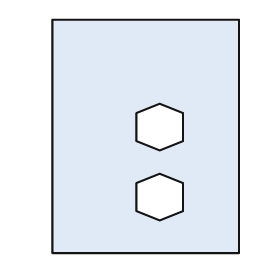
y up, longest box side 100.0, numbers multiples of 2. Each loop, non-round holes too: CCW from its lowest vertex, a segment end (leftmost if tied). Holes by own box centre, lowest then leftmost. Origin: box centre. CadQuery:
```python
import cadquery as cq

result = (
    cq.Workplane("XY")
    .moveTo(-40.0, -50.0)
    .lineTo(40.0, -50.0)
    .lineTo(40.0, 50.0)
    .lineTo(-40.0, 50.0)
    .close()
    .moveTo(6.0, -36.0)
    .lineTo(16.0, -32.0)
    .lineTo(16.0, -20.0)
    .lineTo(6.0, -16.0)
    .lineTo(-4.0, -20.0)
    .lineTo(-4.0, -32.0)
    .close()
    .moveTo(6.0, -6.0)
    .lineTo(16.0, -2.0)
    .lineTo(16.0, 10.0)
    .lineTo(6.0, 14.0)
    .lineTo(-4.0, 10.0)
    .lineTo(-4.0, -2.0)
    .close()
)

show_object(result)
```